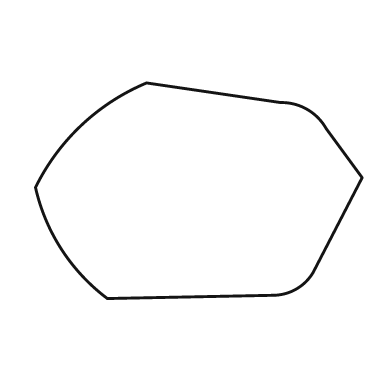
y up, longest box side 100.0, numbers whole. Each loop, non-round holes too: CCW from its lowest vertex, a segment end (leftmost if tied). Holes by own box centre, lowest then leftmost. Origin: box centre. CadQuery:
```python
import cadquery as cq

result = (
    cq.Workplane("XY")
    .moveTo(-28.0, -33.0)
    .lineTo(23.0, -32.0)
    .threePointArc((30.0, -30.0), (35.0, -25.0))
    .lineTo(50.0, 4.0)
    .lineTo(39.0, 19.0)
    .threePointArc((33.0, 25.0), (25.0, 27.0))
    .lineTo(-16.0, 33.0)
    .threePointArc((-36.0, 20.0), (-50.0, 1.0))
    .threePointArc((-42.0, -18.0), (-28.0, -33.0))
    .close()
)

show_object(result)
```